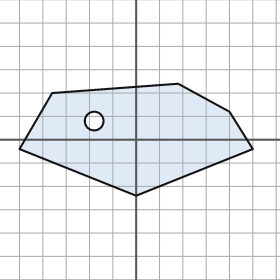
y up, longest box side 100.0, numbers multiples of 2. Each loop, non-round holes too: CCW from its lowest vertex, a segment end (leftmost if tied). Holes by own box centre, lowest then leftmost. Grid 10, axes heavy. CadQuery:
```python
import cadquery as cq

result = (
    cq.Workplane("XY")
    .moveTo(0.0, -24.0)
    .lineTo(50.0, -4.0)
    .lineTo(40.0, 12.0)
    .lineTo(18.0, 24.0)
    .lineTo(-36.0, 20.0)
    .lineTo(-50.0, -4.0)
    .close()
    .moveTo(-18.0, 8.0)
    .circle(4.0)
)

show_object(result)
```